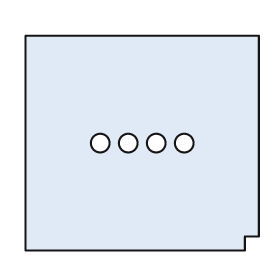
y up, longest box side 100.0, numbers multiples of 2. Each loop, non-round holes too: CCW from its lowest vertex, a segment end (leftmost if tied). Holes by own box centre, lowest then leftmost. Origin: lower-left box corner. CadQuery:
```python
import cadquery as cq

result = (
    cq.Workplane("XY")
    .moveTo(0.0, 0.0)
    .lineTo(94.0, 0.0)
    .lineTo(94.0, 6.0)
    .lineTo(100.0, 6.0)
    .lineTo(100.0, 92.0)
    .lineTo(0.0, 92.0)
    .close()
    .moveTo(32.0, 46.0)
    .circle(4.0)
    .moveTo(44.0, 46.0)
    .circle(4.0)
    .moveTo(56.0, 46.0)
    .circle(4.0)
    .moveTo(68.0, 46.0)
    .circle(4.0)
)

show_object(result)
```